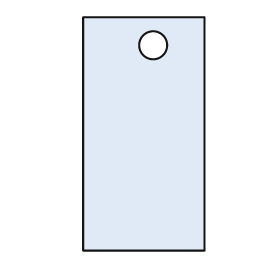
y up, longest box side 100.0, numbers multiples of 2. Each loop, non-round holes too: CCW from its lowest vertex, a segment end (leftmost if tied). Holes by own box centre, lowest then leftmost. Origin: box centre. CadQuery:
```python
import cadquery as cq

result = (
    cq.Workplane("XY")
    .moveTo(-26.0, -50.0)
    .lineTo(26.0, -50.0)
    .lineTo(26.0, 50.0)
    .lineTo(-26.0, 50.0)
    .close()
    .moveTo(4.0, 38.0)
    .circle(6.0)
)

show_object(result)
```